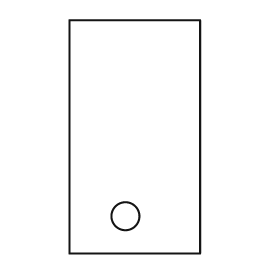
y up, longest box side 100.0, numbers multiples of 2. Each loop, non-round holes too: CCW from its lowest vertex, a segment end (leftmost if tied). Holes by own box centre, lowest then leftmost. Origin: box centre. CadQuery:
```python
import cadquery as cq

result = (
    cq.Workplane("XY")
    .moveTo(-28.0, -50.0)
    .lineTo(28.0, -50.0)
    .lineTo(28.0, 50.0)
    .lineTo(-28.0, 50.0)
    .close()
    .moveTo(-4.0, -34.0)
    .circle(6.0)
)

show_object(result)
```